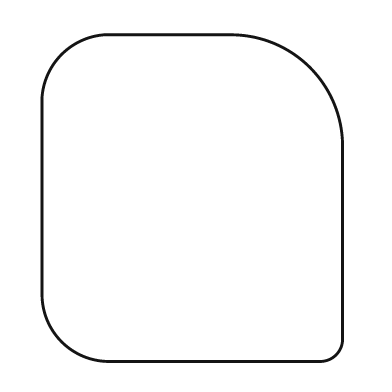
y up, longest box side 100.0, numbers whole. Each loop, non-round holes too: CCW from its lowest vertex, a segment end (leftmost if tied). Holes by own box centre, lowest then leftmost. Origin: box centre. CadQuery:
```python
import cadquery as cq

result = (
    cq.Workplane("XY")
    .moveTo(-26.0, -50.0)
    .lineTo(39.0, -50.0)
    .threePointArc((44.0, -48.0), (46.0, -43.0))
    .lineTo(46.0, 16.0)
    .threePointArc((36.0, 40.0), (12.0, 50.0))
    .lineTo(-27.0, 50.0)
    .threePointArc((-40.0, 44.0), (-46.0, 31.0))
    .lineTo(-46.0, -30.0)
    .threePointArc((-40.0, -44.0), (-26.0, -50.0))
    .close()
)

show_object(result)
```